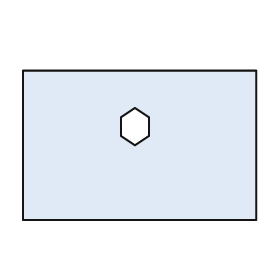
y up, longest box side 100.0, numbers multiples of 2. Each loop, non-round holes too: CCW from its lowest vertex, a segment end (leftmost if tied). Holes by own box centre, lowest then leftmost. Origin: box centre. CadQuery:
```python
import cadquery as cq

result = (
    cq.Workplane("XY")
    .moveTo(-50.0, -32.0)
    .lineTo(50.0, -32.0)
    .lineTo(50.0, 32.0)
    .lineTo(-50.0, 32.0)
    .close()
    .moveTo(-2.0, 0.0)
    .lineTo(4.0, 4.0)
    .lineTo(4.0, 12.0)
    .lineTo(-2.0, 16.0)
    .lineTo(-8.0, 12.0)
    .lineTo(-8.0, 4.0)
    .close()
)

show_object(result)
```